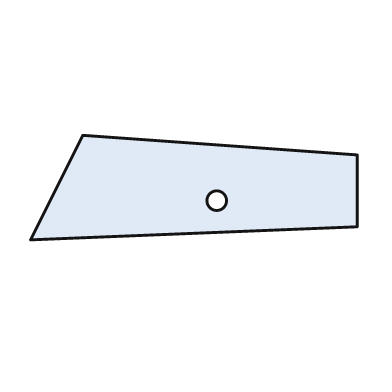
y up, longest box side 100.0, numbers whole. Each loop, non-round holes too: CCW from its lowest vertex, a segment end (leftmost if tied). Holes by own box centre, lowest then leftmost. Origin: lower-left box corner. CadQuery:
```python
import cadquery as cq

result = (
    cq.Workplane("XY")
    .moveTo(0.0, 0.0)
    .lineTo(100.0, 4.0)
    .lineTo(100.0, 26.0)
    .lineTo(16.0, 32.0)
    .close()
    .moveTo(57.0, 12.0)
    .circle(3.0)
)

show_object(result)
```